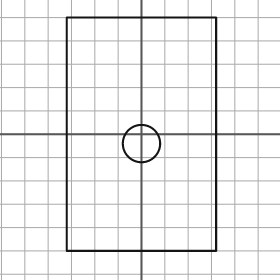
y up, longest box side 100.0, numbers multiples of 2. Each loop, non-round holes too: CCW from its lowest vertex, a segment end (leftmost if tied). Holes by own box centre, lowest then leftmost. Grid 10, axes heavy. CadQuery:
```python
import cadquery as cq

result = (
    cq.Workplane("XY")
    .moveTo(-32.0, -50.0)
    .lineTo(32.0, -50.0)
    .lineTo(32.0, 50.0)
    .lineTo(-32.0, 50.0)
    .close()
    .moveTo(0.0, -4.0)
    .circle(8.0)
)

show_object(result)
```